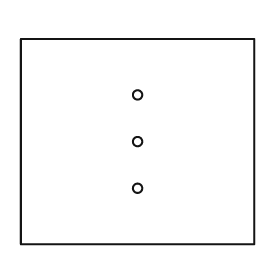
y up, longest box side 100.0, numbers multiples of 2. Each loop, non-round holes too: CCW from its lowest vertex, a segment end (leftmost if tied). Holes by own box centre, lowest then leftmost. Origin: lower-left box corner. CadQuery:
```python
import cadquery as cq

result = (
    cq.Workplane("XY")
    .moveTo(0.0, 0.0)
    .lineTo(100.0, 0.0)
    .lineTo(100.0, 88.0)
    .lineTo(0.0, 88.0)
    .close()
    .moveTo(50.0, 24.0)
    .circle(2.0)
    .moveTo(50.0, 44.0)
    .circle(2.0)
    .moveTo(50.0, 64.0)
    .circle(2.0)
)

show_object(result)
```